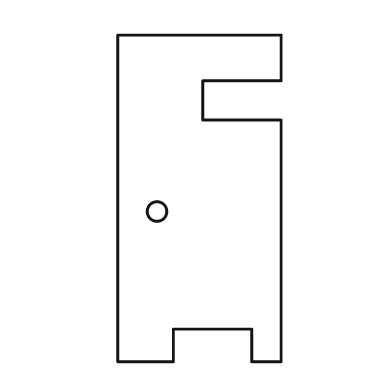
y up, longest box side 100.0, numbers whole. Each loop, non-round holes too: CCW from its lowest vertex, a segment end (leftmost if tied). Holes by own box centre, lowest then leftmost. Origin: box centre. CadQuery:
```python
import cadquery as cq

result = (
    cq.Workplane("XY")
    .moveTo(-25.0, -50.0)
    .lineTo(-8.0, -50.0)
    .lineTo(-8.0, -40.0)
    .lineTo(16.0, -40.0)
    .lineTo(16.0, -50.0)
    .lineTo(25.0, -50.0)
    .lineTo(25.0, 24.0)
    .lineTo(1.0, 24.0)
    .lineTo(1.0, 36.0)
    .lineTo(25.0, 36.0)
    .lineTo(25.0, 50.0)
    .lineTo(-25.0, 50.0)
    .close()
    .moveTo(-13.0, -4.0)
    .circle(3.0)
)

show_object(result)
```